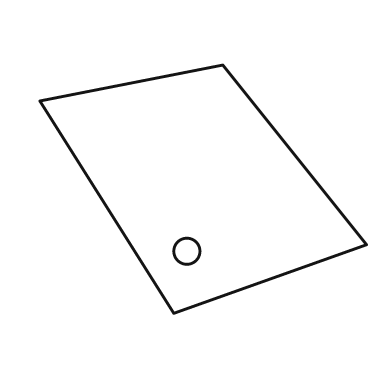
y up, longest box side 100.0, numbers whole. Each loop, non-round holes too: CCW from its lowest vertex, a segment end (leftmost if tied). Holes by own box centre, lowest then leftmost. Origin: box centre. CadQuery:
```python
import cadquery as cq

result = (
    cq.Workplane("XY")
    .moveTo(-9.0, -38.0)
    .lineTo(50.0, -17.0)
    .lineTo(6.0, 38.0)
    .lineTo(-50.0, 27.0)
    .close()
    .moveTo(-5.0, -19.0)
    .circle(4.0)
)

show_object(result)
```